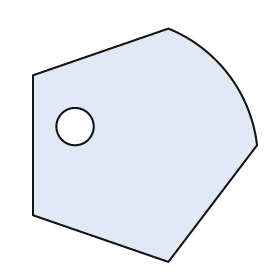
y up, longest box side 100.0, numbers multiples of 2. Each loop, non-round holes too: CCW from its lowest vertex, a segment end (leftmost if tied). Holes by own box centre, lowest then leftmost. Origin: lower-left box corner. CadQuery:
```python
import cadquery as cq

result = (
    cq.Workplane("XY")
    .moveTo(58.0, 0.0)
    .lineTo(96.0, 50.0)
    .threePointArc((84.0, 80.0), (58.0, 100.0))
    .lineTo(0.0, 80.0)
    .lineTo(0.0, 20.0)
    .close()
    .moveTo(18.0, 58.0)
    .circle(8.0)
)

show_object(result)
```